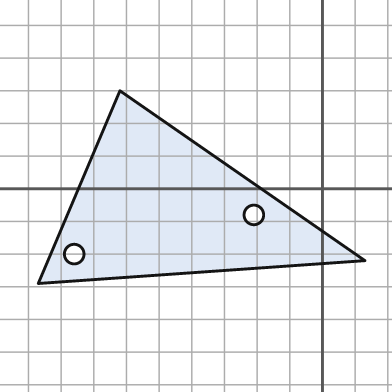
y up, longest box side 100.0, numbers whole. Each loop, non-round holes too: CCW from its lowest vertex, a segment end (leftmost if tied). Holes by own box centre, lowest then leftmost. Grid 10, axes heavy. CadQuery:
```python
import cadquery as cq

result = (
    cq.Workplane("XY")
    .moveTo(-87.0, -29.0)
    .lineTo(13.0, -22.0)
    .lineTo(-62.0, 30.0)
    .close()
    .moveTo(-76.0, -20.0)
    .circle(3.0)
    .moveTo(-21.0, -8.0)
    .circle(3.0)
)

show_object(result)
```